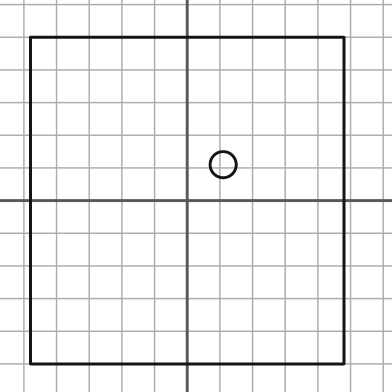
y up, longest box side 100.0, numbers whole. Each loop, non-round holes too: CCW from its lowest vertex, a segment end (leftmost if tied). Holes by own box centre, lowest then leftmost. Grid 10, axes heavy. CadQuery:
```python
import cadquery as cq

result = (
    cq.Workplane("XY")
    .moveTo(-48.0, -50.0)
    .lineTo(48.0, -50.0)
    .lineTo(48.0, 50.0)
    .lineTo(-48.0, 50.0)
    .close()
    .moveTo(11.0, 11.0)
    .circle(4.0)
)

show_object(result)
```